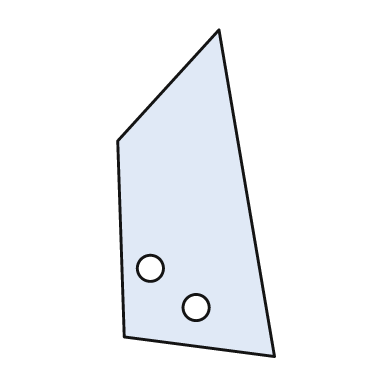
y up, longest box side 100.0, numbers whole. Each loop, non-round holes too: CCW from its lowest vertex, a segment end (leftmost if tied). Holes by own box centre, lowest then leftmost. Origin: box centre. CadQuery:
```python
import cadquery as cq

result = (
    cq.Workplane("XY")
    .moveTo(24.0, -50.0)
    .lineTo(7.0, 50.0)
    .lineTo(-24.0, 16.0)
    .lineTo(-22.0, -44.0)
    .close()
    .moveTo(0.0, -35.0)
    .circle(4.0)
    .moveTo(-14.0, -23.0)
    .circle(4.0)
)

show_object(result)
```